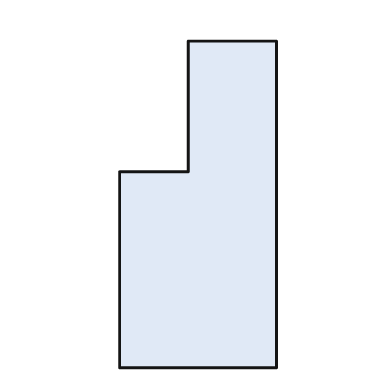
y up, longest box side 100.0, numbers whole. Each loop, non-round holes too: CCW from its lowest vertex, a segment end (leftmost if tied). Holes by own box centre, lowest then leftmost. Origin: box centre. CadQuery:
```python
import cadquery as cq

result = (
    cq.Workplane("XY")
    .moveTo(-24.0, -50.0)
    .lineTo(24.0, -50.0)
    .lineTo(24.0, 50.0)
    .lineTo(-3.0, 50.0)
    .lineTo(-3.0, 10.0)
    .lineTo(-24.0, 10.0)
    .close()
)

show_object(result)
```